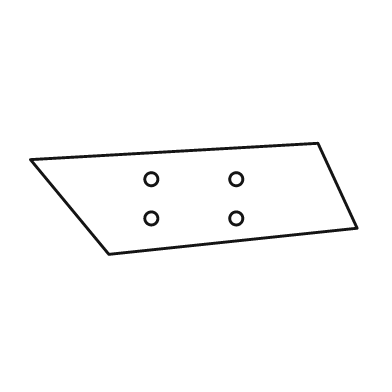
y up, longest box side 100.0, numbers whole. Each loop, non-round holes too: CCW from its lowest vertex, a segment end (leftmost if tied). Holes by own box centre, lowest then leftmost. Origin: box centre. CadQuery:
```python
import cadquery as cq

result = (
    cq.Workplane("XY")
    .moveTo(-26.0, -17.0)
    .lineTo(50.0, -9.0)
    .lineTo(38.0, 17.0)
    .lineTo(-50.0, 12.0)
    .close()
    .moveTo(-13.0, -6.0)
    .circle(2.0)
    .moveTo(13.0, -6.0)
    .circle(2.0)
    .moveTo(-13.0, 6.0)
    .circle(2.0)
    .moveTo(13.0, 6.0)
    .circle(2.0)
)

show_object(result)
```